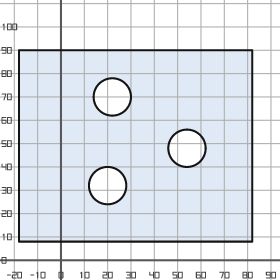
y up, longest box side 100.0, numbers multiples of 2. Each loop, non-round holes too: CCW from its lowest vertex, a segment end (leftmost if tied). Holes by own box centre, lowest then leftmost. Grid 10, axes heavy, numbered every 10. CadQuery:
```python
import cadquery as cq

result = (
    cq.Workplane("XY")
    .moveTo(-18.0, 8.0)
    .lineTo(82.0, 8.0)
    .lineTo(82.0, 90.0)
    .lineTo(-18.0, 90.0)
    .close()
    .moveTo(20.0, 32.0)
    .circle(8.0)
    .moveTo(54.0, 48.0)
    .circle(8.0)
    .moveTo(22.0, 70.0)
    .circle(8.0)
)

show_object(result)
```